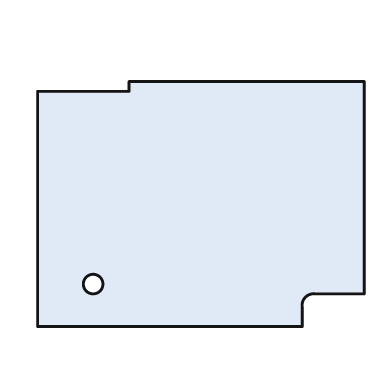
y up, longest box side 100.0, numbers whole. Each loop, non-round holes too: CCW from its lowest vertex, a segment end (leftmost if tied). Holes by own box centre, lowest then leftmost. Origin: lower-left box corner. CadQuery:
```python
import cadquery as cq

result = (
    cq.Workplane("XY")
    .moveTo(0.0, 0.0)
    .lineTo(81.0, 0.0)
    .lineTo(81.0, 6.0)
    .threePointArc((82.0, 9.0), (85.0, 10.0))
    .lineTo(100.0, 10.0)
    .lineTo(100.0, 75.0)
    .lineTo(28.0, 75.0)
    .lineTo(28.0, 72.0)
    .lineTo(0.0, 72.0)
    .close()
    .moveTo(17.0, 13.0)
    .circle(3.0)
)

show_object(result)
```